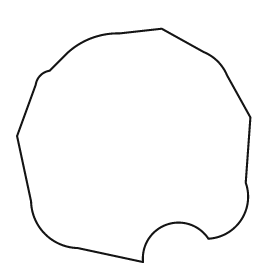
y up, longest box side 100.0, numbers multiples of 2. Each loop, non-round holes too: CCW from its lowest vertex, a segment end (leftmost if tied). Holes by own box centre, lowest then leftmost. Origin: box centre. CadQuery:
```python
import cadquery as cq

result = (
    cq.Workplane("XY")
    .moveTo(4.0, -50.0)
    .threePointArc((14.0, -34.0), (32.0, -40.0))
    .threePointArc((46.0, -32.0), (48.0, -16.0))
    .lineTo(50.0, 12.0)
    .lineTo(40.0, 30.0)
    .threePointArc((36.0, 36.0), (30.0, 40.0))
    .lineTo(12.0, 50.0)
    .lineTo(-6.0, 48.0)
    .threePointArc((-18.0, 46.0), (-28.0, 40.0))
    .lineTo(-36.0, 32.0)
    .threePointArc((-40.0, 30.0), (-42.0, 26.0))
    .lineTo(-50.0, 4.0)
    .lineTo(-44.0, -24.0)
    .threePointArc((-38.0, -38.0), (-24.0, -44.0))
    .close()
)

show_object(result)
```